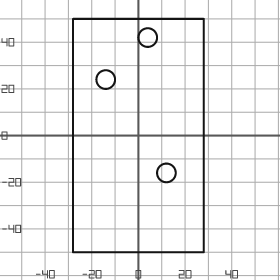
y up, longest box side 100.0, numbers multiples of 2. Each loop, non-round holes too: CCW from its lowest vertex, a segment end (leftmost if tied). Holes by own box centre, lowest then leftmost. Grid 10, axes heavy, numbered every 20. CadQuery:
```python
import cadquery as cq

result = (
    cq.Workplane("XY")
    .moveTo(-28.0, -50.0)
    .lineTo(28.0, -50.0)
    .lineTo(28.0, 50.0)
    .lineTo(-28.0, 50.0)
    .close()
    .moveTo(12.0, -16.0)
    .circle(4.0)
    .moveTo(-14.0, 24.0)
    .circle(4.0)
    .moveTo(4.0, 42.0)
    .circle(4.0)
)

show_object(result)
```